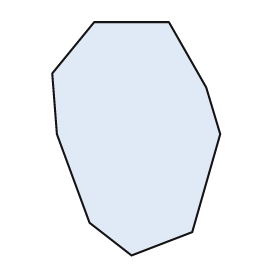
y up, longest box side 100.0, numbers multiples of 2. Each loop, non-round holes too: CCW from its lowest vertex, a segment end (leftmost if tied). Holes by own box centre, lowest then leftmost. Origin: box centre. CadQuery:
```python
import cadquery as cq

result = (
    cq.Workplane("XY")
    .moveTo(-2.0, -50.0)
    .lineTo(24.0, -40.0)
    .lineTo(36.0, 2.0)
    .lineTo(30.0, 22.0)
    .lineTo(14.0, 50.0)
    .lineTo(-18.0, 50.0)
    .lineTo(-36.0, 28.0)
    .lineTo(-34.0, 2.0)
    .lineTo(-20.0, -36.0)
    .close()
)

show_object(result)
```